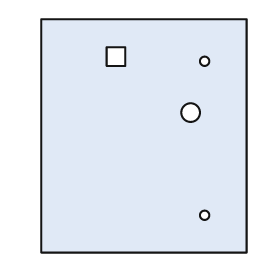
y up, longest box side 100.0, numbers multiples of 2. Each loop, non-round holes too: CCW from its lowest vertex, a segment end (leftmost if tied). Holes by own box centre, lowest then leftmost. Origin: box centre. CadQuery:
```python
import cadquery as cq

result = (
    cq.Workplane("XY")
    .moveTo(-44.0, -50.0)
    .lineTo(44.0, -50.0)
    .lineTo(44.0, 50.0)
    .lineTo(-44.0, 50.0)
    .close()
    .moveTo(26.0, -34.0)
    .circle(2.0)
    .moveTo(20.0, 10.0)
    .circle(4.0)
    .moveTo(26.0, 32.0)
    .circle(2.0)
    .moveTo(-16.0, 30.0)
    .lineTo(-8.0, 30.0)
    .lineTo(-8.0, 38.0)
    .lineTo(-16.0, 38.0)
    .close()
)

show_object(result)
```